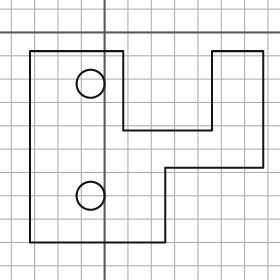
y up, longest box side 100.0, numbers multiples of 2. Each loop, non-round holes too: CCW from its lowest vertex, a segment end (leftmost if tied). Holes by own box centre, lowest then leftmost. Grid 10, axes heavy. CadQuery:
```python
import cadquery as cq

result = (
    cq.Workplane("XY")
    .moveTo(-32.0, -90.0)
    .lineTo(26.0, -90.0)
    .lineTo(26.0, -58.0)
    .lineTo(68.0, -58.0)
    .lineTo(68.0, -8.0)
    .lineTo(46.0, -8.0)
    .lineTo(46.0, -42.0)
    .lineTo(8.0, -42.0)
    .lineTo(8.0, -8.0)
    .lineTo(-32.0, -8.0)
    .close()
    .moveTo(-6.0, -70.0)
    .circle(6.0)
    .moveTo(-6.0, -22.0)
    .circle(6.0)
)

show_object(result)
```